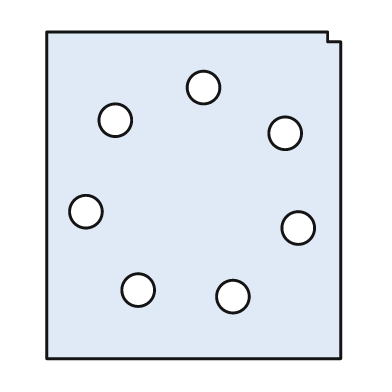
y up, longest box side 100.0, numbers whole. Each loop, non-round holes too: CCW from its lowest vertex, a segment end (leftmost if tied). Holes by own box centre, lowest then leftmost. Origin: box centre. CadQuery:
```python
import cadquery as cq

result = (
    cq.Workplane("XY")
    .moveTo(-45.0, -50.0)
    .lineTo(45.0, -50.0)
    .lineTo(45.0, 47.0)
    .lineTo(41.0, 47.0)
    .lineTo(41.0, 50.0)
    .lineTo(-45.0, 50.0)
    .close()
    .moveTo(12.0, -31.0)
    .circle(5.0)
    .moveTo(-17.0, -29.0)
    .circle(5.0)
    .moveTo(32.0, -10.0)
    .circle(5.0)
    .moveTo(-33.0, -5.0)
    .circle(5.0)
    .moveTo(28.0, 19.0)
    .circle(5.0)
    .moveTo(-24.0, 23.0)
    .circle(5.0)
    .moveTo(3.0, 33.0)
    .circle(5.0)
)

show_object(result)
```